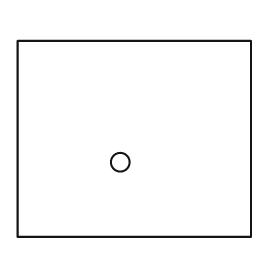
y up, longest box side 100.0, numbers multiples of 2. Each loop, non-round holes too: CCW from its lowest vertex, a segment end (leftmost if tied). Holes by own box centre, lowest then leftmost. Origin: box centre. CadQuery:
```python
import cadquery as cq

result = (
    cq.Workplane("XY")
    .moveTo(-50.0, -42.0)
    .lineTo(50.0, -42.0)
    .lineTo(50.0, 42.0)
    .lineTo(-50.0, 42.0)
    .close()
    .moveTo(-6.0, -10.0)
    .circle(4.0)
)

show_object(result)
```